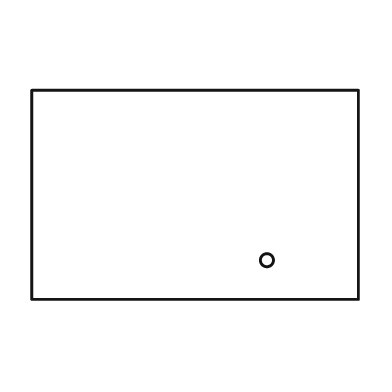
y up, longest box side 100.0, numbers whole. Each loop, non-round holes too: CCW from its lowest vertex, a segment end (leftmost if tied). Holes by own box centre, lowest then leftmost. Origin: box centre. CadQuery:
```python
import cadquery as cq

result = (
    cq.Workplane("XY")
    .moveTo(-50.0, -32.0)
    .lineTo(50.0, -32.0)
    .lineTo(50.0, 32.0)
    .lineTo(-50.0, 32.0)
    .close()
    .moveTo(22.0, -20.0)
    .circle(2.0)
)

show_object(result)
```